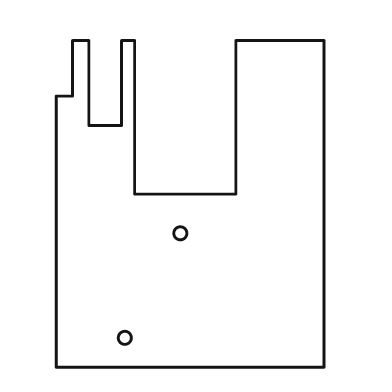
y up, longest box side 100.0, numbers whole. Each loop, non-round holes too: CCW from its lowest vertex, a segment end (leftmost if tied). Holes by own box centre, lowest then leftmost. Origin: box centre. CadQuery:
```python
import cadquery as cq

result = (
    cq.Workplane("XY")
    .moveTo(-41.0, -50.0)
    .lineTo(41.0, -50.0)
    .lineTo(41.0, 50.0)
    .lineTo(14.0, 50.0)
    .lineTo(14.0, 3.0)
    .lineTo(-17.0, 3.0)
    .lineTo(-17.0, 50.0)
    .lineTo(-21.0, 50.0)
    .lineTo(-21.0, 24.0)
    .lineTo(-31.0, 24.0)
    .lineTo(-31.0, 50.0)
    .lineTo(-36.0, 50.0)
    .lineTo(-36.0, 33.0)
    .lineTo(-41.0, 33.0)
    .close()
    .moveTo(-20.0, -41.0)
    .circle(2.0)
    .moveTo(-3.0, -9.0)
    .circle(2.0)
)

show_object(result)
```